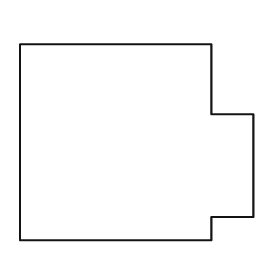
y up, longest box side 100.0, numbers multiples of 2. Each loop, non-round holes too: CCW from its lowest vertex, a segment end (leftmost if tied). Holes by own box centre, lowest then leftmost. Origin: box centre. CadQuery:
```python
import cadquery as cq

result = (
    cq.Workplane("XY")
    .moveTo(-50.0, -42.0)
    .lineTo(32.0, -42.0)
    .lineTo(32.0, -32.0)
    .lineTo(50.0, -32.0)
    .lineTo(50.0, 12.0)
    .lineTo(32.0, 12.0)
    .lineTo(32.0, 42.0)
    .lineTo(-50.0, 42.0)
    .close()
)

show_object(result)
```